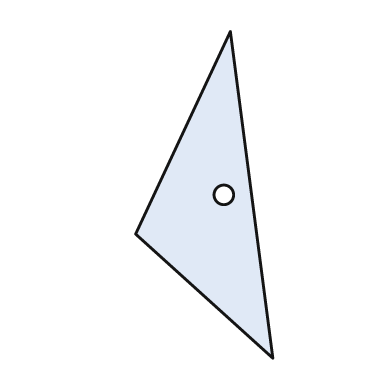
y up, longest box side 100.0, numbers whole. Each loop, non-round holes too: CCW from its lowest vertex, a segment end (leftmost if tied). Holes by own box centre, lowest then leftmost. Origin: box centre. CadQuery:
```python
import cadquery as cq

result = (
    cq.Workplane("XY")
    .moveTo(21.0, -50.0)
    .lineTo(8.0, 50.0)
    .lineTo(-21.0, -12.0)
    .close()
    .moveTo(6.0, 0.0)
    .circle(3.0)
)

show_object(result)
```